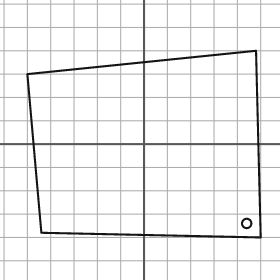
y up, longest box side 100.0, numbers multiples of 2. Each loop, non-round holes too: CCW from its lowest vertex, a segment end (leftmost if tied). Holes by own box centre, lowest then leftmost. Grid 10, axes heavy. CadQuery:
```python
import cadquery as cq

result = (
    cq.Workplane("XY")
    .moveTo(50.0, -40.0)
    .lineTo(48.0, 40.0)
    .lineTo(-50.0, 30.0)
    .lineTo(-44.0, -38.0)
    .close()
    .moveTo(44.0, -34.0)
    .circle(2.0)
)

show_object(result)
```